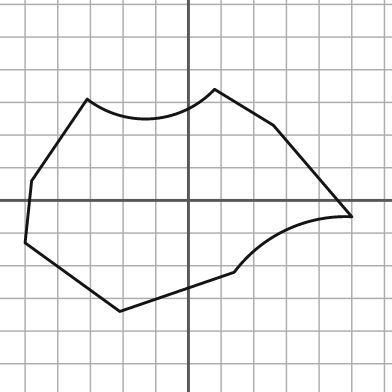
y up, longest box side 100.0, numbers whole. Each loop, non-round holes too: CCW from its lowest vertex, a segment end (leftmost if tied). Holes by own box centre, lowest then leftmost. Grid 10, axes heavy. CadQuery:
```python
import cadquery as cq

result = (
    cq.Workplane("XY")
    .moveTo(-21.0, -34.0)
    .lineTo(14.0, -22.0)
    .threePointArc((30.0, -9.0), (50.0, -5.0))
    .lineTo(26.0, 23.0)
    .lineTo(8.0, 34.0)
    .threePointArc((-11.0, 25.0), (-31.0, 31.0))
    .lineTo(-48.0, 6.0)
    .lineTo(-50.0, -13.0)
    .close()
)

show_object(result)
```